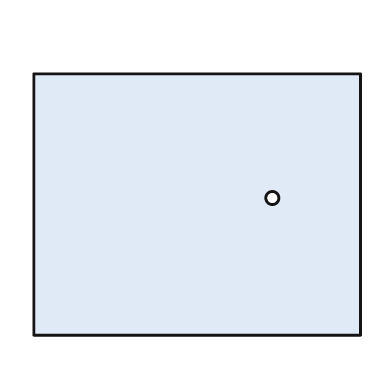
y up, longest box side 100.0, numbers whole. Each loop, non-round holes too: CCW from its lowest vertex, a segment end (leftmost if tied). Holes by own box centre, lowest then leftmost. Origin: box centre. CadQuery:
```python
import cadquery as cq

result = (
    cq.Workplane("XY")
    .moveTo(-50.0, -40.0)
    .lineTo(50.0, -40.0)
    .lineTo(50.0, 40.0)
    .lineTo(-50.0, 40.0)
    .close()
    .moveTo(23.0, 2.0)
    .circle(2.0)
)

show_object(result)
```